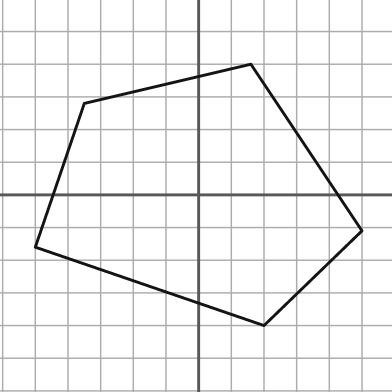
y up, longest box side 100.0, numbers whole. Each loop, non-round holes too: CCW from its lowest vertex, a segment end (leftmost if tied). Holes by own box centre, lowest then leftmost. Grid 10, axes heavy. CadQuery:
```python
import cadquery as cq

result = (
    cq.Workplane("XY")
    .moveTo(20.0, -40.0)
    .lineTo(50.0, -11.0)
    .lineTo(16.0, 40.0)
    .lineTo(-35.0, 28.0)
    .lineTo(-50.0, -16.0)
    .close()
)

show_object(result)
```